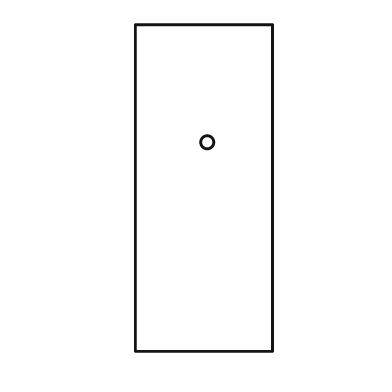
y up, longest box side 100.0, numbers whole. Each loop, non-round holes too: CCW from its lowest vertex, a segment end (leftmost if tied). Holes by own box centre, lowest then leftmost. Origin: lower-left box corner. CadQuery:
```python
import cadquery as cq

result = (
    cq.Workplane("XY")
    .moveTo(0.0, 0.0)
    .lineTo(42.0, 0.0)
    .lineTo(42.0, 100.0)
    .lineTo(0.0, 100.0)
    .close()
    .moveTo(22.0, 64.0)
    .circle(2.0)
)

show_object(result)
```